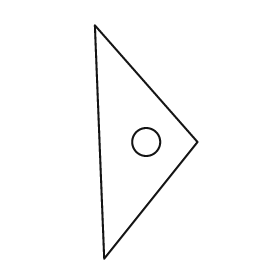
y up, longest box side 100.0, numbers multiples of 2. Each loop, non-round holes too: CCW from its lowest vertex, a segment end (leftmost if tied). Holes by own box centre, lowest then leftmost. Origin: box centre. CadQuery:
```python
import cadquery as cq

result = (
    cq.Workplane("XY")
    .moveTo(-18.0, -50.0)
    .lineTo(22.0, 0.0)
    .lineTo(-22.0, 50.0)
    .close()
    .moveTo(0.0, 0.0)
    .circle(6.0)
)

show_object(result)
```